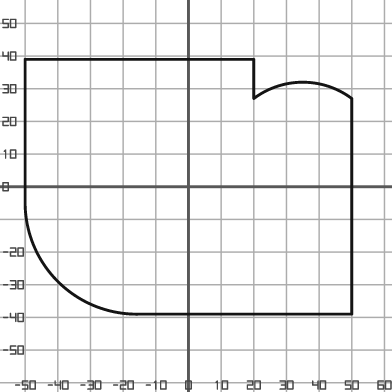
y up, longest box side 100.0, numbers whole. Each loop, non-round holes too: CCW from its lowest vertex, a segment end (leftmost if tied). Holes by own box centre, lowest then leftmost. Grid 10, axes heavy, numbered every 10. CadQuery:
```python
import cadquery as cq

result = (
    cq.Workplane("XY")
    .moveTo(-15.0, -39.0)
    .lineTo(50.0, -39.0)
    .lineTo(50.0, 27.0)
    .threePointArc((35.0, 32.0), (20.0, 27.0))
    .lineTo(20.0, 39.0)
    .lineTo(-50.0, 39.0)
    .lineTo(-50.0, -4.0)
    .threePointArc((-40.0, -29.0), (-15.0, -39.0))
    .close()
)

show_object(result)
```